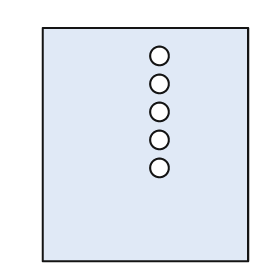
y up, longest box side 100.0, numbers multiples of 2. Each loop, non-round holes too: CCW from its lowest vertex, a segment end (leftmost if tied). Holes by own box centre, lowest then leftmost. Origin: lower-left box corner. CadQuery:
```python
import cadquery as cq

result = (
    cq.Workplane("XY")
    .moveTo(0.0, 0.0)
    .lineTo(88.0, 0.0)
    .lineTo(88.0, 100.0)
    .lineTo(0.0, 100.0)
    .close()
    .moveTo(50.0, 40.0)
    .circle(4.0)
    .moveTo(50.0, 52.0)
    .circle(4.0)
    .moveTo(50.0, 64.0)
    .circle(4.0)
    .moveTo(50.0, 76.0)
    .circle(4.0)
    .moveTo(50.0, 88.0)
    .circle(4.0)
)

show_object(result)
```